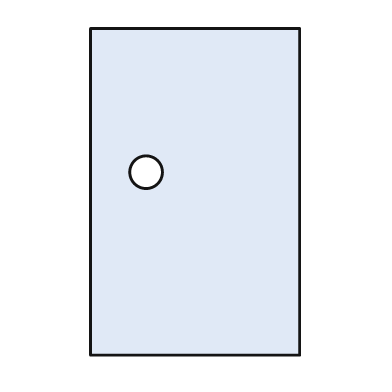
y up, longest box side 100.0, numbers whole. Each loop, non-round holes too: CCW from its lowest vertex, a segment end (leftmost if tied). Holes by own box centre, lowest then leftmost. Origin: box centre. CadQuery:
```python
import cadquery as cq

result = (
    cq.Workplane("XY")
    .moveTo(-32.0, -50.0)
    .lineTo(32.0, -50.0)
    .lineTo(32.0, 50.0)
    .lineTo(-32.0, 50.0)
    .close()
    .moveTo(-15.0, 6.0)
    .circle(5.0)
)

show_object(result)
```